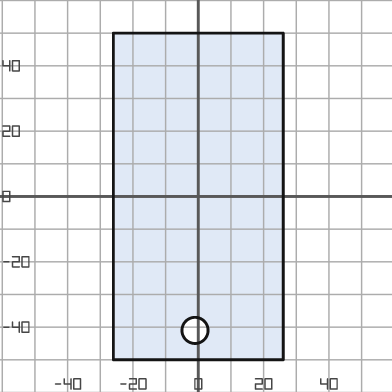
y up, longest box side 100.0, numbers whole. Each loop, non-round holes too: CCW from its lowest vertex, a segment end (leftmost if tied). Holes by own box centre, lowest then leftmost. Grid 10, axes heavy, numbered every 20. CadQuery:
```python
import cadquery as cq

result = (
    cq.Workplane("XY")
    .moveTo(-26.0, -50.0)
    .lineTo(26.0, -50.0)
    .lineTo(26.0, 50.0)
    .lineTo(-26.0, 50.0)
    .close()
    .moveTo(-1.0, -41.0)
    .circle(4.0)
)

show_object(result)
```